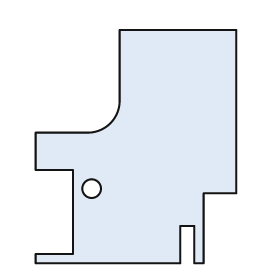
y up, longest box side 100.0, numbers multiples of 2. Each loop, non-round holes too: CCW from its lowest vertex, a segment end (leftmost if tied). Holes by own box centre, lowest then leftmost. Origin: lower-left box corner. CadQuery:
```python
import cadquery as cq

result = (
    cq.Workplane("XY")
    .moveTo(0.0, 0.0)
    .lineTo(62.0, 0.0)
    .lineTo(62.0, 16.0)
    .lineTo(68.0, 16.0)
    .lineTo(68.0, 0.0)
    .lineTo(72.0, 0.0)
    .lineTo(72.0, 30.0)
    .lineTo(86.0, 30.0)
    .lineTo(86.0, 100.0)
    .lineTo(36.0, 100.0)
    .lineTo(36.0, 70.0)
    .threePointArc((32.0, 60.0), (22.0, 56.0))
    .lineTo(0.0, 56.0)
    .lineTo(0.0, 40.0)
    .lineTo(16.0, 40.0)
    .lineTo(16.0, 4.0)
    .lineTo(0.0, 4.0)
    .close()
    .moveTo(24.0, 32.0)
    .circle(4.0)
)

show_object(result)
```